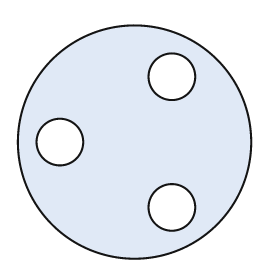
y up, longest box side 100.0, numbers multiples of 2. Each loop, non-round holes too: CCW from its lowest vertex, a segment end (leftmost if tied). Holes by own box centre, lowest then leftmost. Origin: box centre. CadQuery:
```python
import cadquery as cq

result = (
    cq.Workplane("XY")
    .moveTo(0.0, 0.0)
    .circle(50.0)
    .moveTo(16.0, -28.0)
    .circle(10.0)
    .moveTo(-32.0, 0.0)
    .circle(10.0)
    .moveTo(16.0, 28.0)
    .circle(10.0)
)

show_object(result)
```